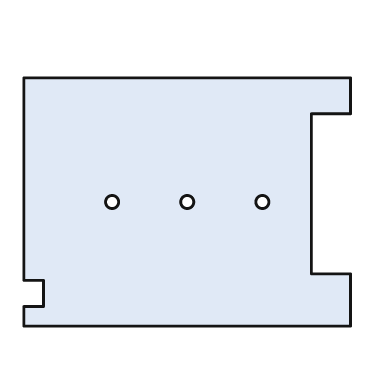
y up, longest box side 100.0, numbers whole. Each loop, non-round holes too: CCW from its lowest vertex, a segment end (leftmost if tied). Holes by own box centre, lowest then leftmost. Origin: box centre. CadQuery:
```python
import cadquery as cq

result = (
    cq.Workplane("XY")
    .moveTo(-50.0, -38.0)
    .lineTo(50.0, -38.0)
    .lineTo(50.0, -22.0)
    .lineTo(38.0, -22.0)
    .lineTo(38.0, 27.0)
    .lineTo(50.0, 27.0)
    .lineTo(50.0, 38.0)
    .lineTo(-50.0, 38.0)
    .lineTo(-50.0, -24.0)
    .lineTo(-44.0, -24.0)
    .lineTo(-44.0, -32.0)
    .lineTo(-50.0, -32.0)
    .close()
    .moveTo(-23.0, 0.0)
    .circle(2.0)
    .moveTo(0.0, 0.0)
    .circle(2.0)
    .moveTo(23.0, 0.0)
    .circle(2.0)
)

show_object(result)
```